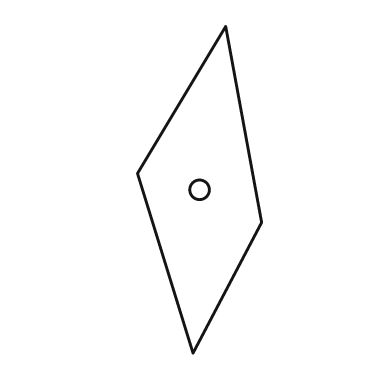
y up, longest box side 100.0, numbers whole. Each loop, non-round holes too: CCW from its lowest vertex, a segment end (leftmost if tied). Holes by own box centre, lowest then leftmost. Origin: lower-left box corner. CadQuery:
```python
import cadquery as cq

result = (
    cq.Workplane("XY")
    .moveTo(17.0, 0.0)
    .lineTo(38.0, 40.0)
    .lineTo(27.0, 100.0)
    .lineTo(0.0, 55.0)
    .close()
    .moveTo(19.0, 50.0)
    .circle(3.0)
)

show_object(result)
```